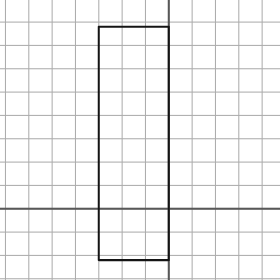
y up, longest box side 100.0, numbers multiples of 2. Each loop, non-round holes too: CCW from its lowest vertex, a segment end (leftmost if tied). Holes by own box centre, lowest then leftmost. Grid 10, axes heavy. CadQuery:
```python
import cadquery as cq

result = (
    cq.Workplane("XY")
    .moveTo(-30.0, -22.0)
    .lineTo(0.0, -22.0)
    .lineTo(0.0, 78.0)
    .lineTo(-30.0, 78.0)
    .close()
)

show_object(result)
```